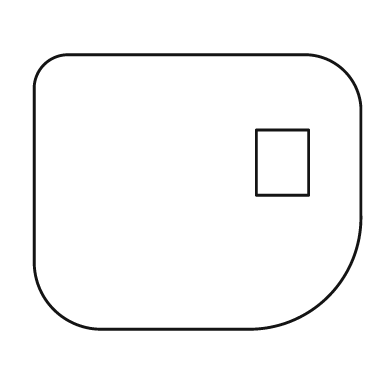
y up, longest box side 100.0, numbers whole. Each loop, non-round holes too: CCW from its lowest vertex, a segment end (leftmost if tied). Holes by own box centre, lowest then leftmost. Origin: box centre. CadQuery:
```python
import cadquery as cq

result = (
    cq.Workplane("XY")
    .moveTo(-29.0, -42.0)
    .lineTo(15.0, -42.0)
    .threePointArc((40.0, -32.0), (50.0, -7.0))
    .lineTo(50.0, 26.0)
    .threePointArc((45.0, 37.0), (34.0, 42.0))
    .lineTo(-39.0, 42.0)
    .threePointArc((-47.0, 39.0), (-50.0, 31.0))
    .lineTo(-50.0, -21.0)
    .threePointArc((-44.0, -36.0), (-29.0, -42.0))
    .close()
    .moveTo(18.0, -1.0)
    .lineTo(34.0, -1.0)
    .lineTo(34.0, 19.0)
    .lineTo(18.0, 19.0)
    .close()
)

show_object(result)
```